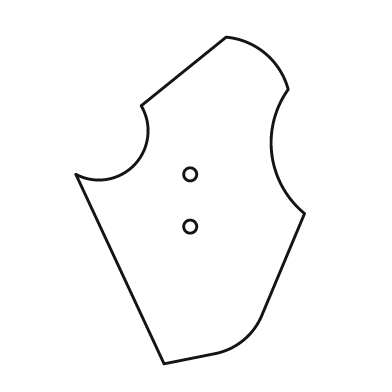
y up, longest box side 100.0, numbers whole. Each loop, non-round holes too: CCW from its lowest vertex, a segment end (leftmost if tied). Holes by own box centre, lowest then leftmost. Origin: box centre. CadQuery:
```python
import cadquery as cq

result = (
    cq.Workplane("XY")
    .moveTo(-8.0, -50.0)
    .lineTo(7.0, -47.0)
    .threePointArc((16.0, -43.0), (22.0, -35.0))
    .lineTo(35.0, -4.0)
    .threePointArc((25.0, 14.0), (30.0, 34.0))
    .threePointArc((23.0, 45.0), (11.0, 50.0))
    .lineTo(-15.0, 29.0)
    .threePointArc((-17.0, 11.0), (-35.0, 8.0))
    .close()
    .moveTo(0.0, -8.0)
    .circle(2.0)
    .moveTo(0.0, 8.0)
    .circle(2.0)
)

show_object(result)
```